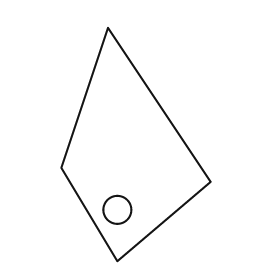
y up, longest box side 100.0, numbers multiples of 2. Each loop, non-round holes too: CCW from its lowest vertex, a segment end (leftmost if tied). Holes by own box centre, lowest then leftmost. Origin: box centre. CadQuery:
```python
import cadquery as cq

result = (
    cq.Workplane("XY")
    .moveTo(-8.0, -50.0)
    .lineTo(32.0, -16.0)
    .lineTo(-12.0, 50.0)
    .lineTo(-32.0, -10.0)
    .close()
    .moveTo(-8.0, -28.0)
    .circle(6.0)
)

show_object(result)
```